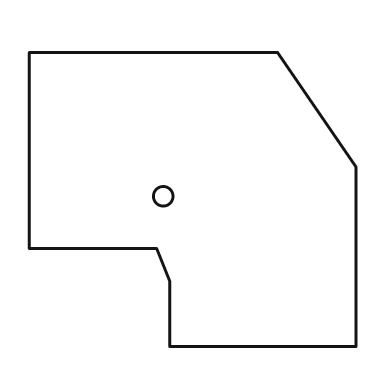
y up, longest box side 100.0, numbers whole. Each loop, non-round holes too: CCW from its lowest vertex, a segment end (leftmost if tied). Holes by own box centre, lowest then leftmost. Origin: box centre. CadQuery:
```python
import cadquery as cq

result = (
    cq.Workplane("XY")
    .moveTo(-7.0, -45.0)
    .lineTo(50.0, -45.0)
    .lineTo(50.0, 10.0)
    .lineTo(26.0, 45.0)
    .lineTo(-50.0, 45.0)
    .lineTo(-50.0, -15.0)
    .lineTo(-11.0, -15.0)
    .lineTo(-7.0, -25.0)
    .close()
    .moveTo(-9.0, 1.0)
    .circle(3.0)
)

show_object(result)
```